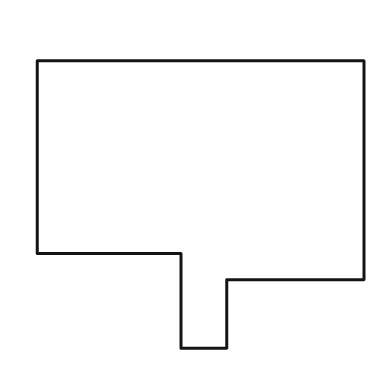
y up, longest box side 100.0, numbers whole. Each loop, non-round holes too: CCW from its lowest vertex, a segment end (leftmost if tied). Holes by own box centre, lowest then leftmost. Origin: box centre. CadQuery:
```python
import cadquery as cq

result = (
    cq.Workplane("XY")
    .moveTo(-6.0, -44.0)
    .lineTo(8.0, -44.0)
    .lineTo(8.0, -23.0)
    .lineTo(50.0, -23.0)
    .lineTo(50.0, 44.0)
    .lineTo(-50.0, 44.0)
    .lineTo(-50.0, -15.0)
    .lineTo(-6.0, -15.0)
    .close()
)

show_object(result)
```